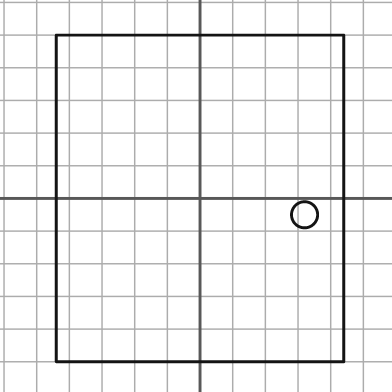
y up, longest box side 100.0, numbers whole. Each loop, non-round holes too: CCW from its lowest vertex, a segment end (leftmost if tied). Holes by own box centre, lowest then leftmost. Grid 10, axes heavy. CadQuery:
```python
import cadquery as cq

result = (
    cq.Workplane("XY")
    .moveTo(-44.0, -50.0)
    .lineTo(44.0, -50.0)
    .lineTo(44.0, 50.0)
    .lineTo(-44.0, 50.0)
    .close()
    .moveTo(32.0, -5.0)
    .circle(4.0)
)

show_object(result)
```